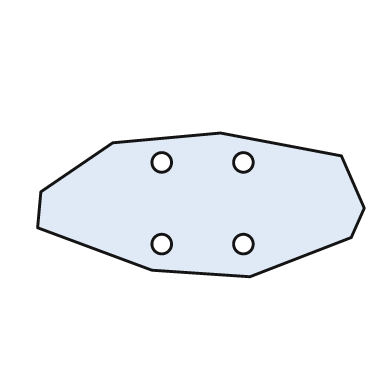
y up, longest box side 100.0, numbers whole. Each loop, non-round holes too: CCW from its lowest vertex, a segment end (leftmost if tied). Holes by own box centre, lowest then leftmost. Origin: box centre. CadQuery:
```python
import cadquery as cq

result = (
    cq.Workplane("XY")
    .moveTo(15.0, -22.0)
    .lineTo(46.0, -10.0)
    .lineTo(50.0, -1.0)
    .lineTo(43.0, 15.0)
    .lineTo(6.0, 22.0)
    .lineTo(-27.0, 19.0)
    .lineTo(-49.0, 4.0)
    .lineTo(-50.0, -7.0)
    .lineTo(-15.0, -20.0)
    .close()
    .moveTo(-12.0, -12.0)
    .circle(3.0)
    .moveTo(13.0, -12.0)
    .circle(3.0)
    .moveTo(-12.0, 13.0)
    .circle(3.0)
    .moveTo(13.0, 13.0)
    .circle(3.0)
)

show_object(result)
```